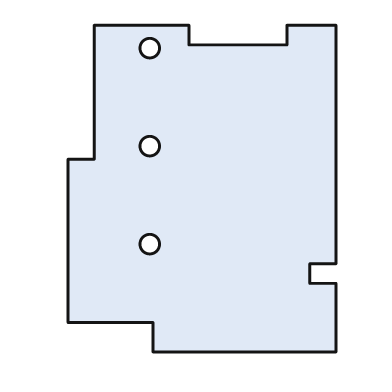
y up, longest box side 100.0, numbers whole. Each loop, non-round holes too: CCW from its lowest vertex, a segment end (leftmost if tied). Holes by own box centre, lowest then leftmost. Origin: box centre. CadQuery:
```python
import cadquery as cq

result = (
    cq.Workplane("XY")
    .moveTo(-15.0, -50.0)
    .lineTo(41.0, -50.0)
    .lineTo(41.0, -29.0)
    .lineTo(33.0, -29.0)
    .lineTo(33.0, -23.0)
    .lineTo(41.0, -23.0)
    .lineTo(41.0, 50.0)
    .lineTo(26.0, 50.0)
    .lineTo(26.0, 44.0)
    .lineTo(-4.0, 44.0)
    .lineTo(-4.0, 50.0)
    .lineTo(-33.0, 50.0)
    .lineTo(-33.0, 9.0)
    .lineTo(-41.0, 9.0)
    .lineTo(-41.0, -41.0)
    .lineTo(-15.0, -41.0)
    .close()
    .moveTo(-16.0, -17.0)
    .circle(3.0)
    .moveTo(-16.0, 13.0)
    .circle(3.0)
    .moveTo(-16.0, 43.0)
    .circle(3.0)
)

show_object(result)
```